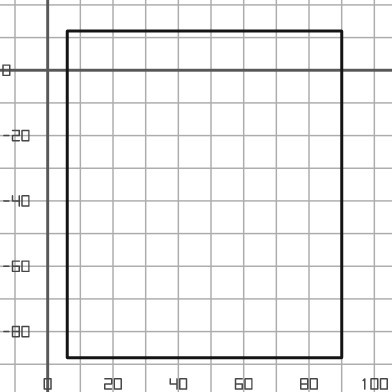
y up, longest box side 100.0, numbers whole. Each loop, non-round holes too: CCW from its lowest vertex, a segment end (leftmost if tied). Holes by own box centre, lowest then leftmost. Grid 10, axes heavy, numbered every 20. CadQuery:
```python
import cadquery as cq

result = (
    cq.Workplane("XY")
    .moveTo(6.0, -88.0)
    .lineTo(90.0, -88.0)
    .lineTo(90.0, 12.0)
    .lineTo(6.0, 12.0)
    .close()
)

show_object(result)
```